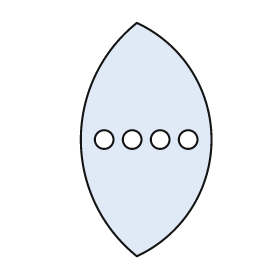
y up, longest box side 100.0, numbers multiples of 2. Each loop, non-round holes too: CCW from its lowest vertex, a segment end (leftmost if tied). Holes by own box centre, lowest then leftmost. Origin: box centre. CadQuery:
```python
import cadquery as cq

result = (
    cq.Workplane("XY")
    .moveTo(-4.0, -50.0)
    .threePointArc((28.0, 0.0), (-4.0, 50.0))
    .threePointArc((-28.0, 0.0), (-4.0, -50.0))
    .close()
    .moveTo(-18.0, 0.0)
    .circle(4.0)
    .moveTo(-6.0, 0.0)
    .circle(4.0)
    .moveTo(6.0, 0.0)
    .circle(4.0)
    .moveTo(18.0, 0.0)
    .circle(4.0)
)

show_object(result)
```